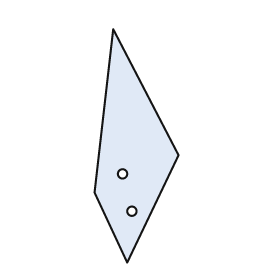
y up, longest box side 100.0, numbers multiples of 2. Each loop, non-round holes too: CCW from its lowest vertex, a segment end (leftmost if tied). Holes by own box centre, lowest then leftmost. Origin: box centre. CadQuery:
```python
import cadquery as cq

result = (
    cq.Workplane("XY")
    .moveTo(-4.0, -50.0)
    .lineTo(18.0, -4.0)
    .lineTo(-10.0, 50.0)
    .lineTo(-18.0, -20.0)
    .close()
    .moveTo(-2.0, -28.0)
    .circle(2.0)
    .moveTo(-6.0, -12.0)
    .circle(2.0)
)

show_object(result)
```